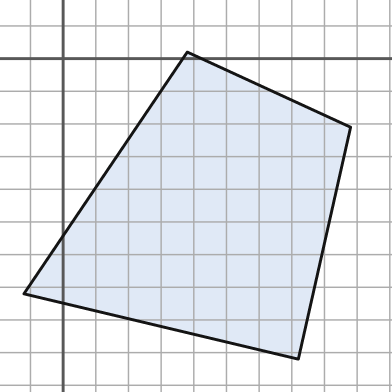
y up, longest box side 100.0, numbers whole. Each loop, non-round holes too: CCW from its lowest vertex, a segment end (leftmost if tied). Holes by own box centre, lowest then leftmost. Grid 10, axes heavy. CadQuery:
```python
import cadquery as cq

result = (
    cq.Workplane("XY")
    .moveTo(72.0, -92.0)
    .lineTo(88.0, -21.0)
    .lineTo(38.0, 2.0)
    .lineTo(-12.0, -72.0)
    .close()
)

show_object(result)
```